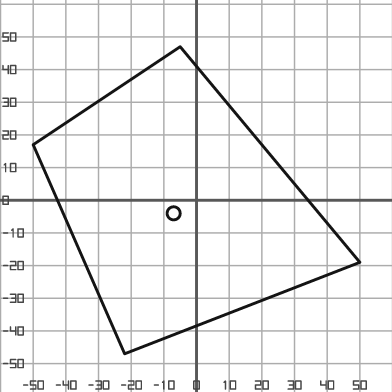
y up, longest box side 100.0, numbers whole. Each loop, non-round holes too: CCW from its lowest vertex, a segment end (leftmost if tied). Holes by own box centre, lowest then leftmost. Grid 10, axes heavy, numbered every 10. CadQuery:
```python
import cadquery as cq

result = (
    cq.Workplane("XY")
    .moveTo(-22.0, -47.0)
    .lineTo(50.0, -19.0)
    .lineTo(-5.0, 47.0)
    .lineTo(-50.0, 17.0)
    .close()
    .moveTo(-7.0, -4.0)
    .circle(2.0)
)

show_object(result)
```